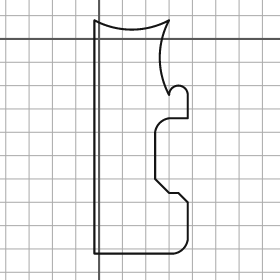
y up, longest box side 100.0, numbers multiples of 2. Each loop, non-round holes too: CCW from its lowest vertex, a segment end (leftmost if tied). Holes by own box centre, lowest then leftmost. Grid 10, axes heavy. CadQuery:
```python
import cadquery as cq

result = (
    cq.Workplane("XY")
    .moveTo(-2.0, -92.0)
    .lineTo(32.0, -92.0)
    .threePointArc((36.0, -90.0), (38.0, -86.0))
    .lineTo(38.0, -70.0)
    .lineTo(34.0, -66.0)
    .lineTo(30.0, -66.0)
    .lineTo(24.0, -60.0)
    .lineTo(24.0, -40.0)
    .threePointArc((26.0, -36.0), (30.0, -34.0))
    .lineTo(38.0, -34.0)
    .lineTo(38.0, -24.0)
    .threePointArc((34.0, -20.0), (30.0, -24.0))
    .threePointArc((26.0, -8.0), (30.0, 8.0))
    .threePointArc((14.0, 4.0), (-2.0, 8.0))
    .close()
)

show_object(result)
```